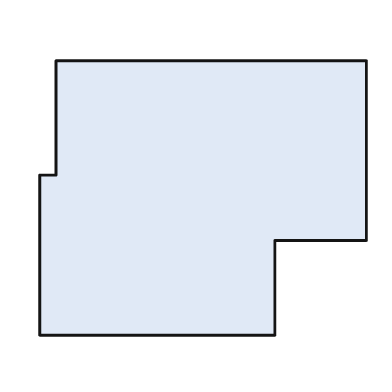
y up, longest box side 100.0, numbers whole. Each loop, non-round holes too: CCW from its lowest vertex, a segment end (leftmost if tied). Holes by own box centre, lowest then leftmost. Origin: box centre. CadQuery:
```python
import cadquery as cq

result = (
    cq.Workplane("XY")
    .moveTo(-50.0, -42.0)
    .lineTo(22.0, -42.0)
    .lineTo(22.0, -13.0)
    .lineTo(50.0, -13.0)
    .lineTo(50.0, 42.0)
    .lineTo(-45.0, 42.0)
    .lineTo(-45.0, 7.0)
    .lineTo(-50.0, 7.0)
    .close()
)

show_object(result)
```